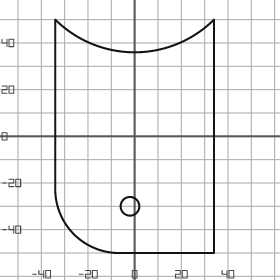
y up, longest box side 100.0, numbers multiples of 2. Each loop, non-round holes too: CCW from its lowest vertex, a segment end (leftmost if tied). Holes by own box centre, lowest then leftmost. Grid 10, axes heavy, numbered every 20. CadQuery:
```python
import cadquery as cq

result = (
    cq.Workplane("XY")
    .moveTo(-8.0, -50.0)
    .lineTo(34.0, -50.0)
    .lineTo(34.0, 50.0)
    .threePointArc((0.0, 36.0), (-34.0, 50.0))
    .lineTo(-34.0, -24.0)
    .threePointArc((-26.0, -42.0), (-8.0, -50.0))
    .close()
    .moveTo(-2.0, -30.0)
    .circle(4.0)
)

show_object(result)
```